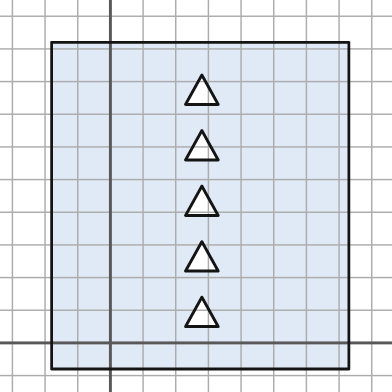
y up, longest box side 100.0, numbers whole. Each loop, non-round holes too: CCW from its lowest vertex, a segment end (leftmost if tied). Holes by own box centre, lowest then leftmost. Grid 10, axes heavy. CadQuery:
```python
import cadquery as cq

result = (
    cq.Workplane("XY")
    .moveTo(-18.0, -8.0)
    .lineTo(73.0, -8.0)
    .lineTo(73.0, 92.0)
    .lineTo(-18.0, 92.0)
    .close()
    .moveTo(23.0, 5.0)
    .lineTo(33.0, 5.0)
    .lineTo(28.0, 14.0)
    .close()
    .moveTo(23.0, 22.0)
    .lineTo(33.0, 22.0)
    .lineTo(28.0, 31.0)
    .close()
    .moveTo(23.0, 39.0)
    .lineTo(33.0, 39.0)
    .lineTo(28.0, 48.0)
    .close()
    .moveTo(23.0, 56.0)
    .lineTo(33.0, 56.0)
    .lineTo(28.0, 65.0)
    .close()
    .moveTo(23.0, 73.0)
    .lineTo(33.0, 73.0)
    .lineTo(28.0, 82.0)
    .close()
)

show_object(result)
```